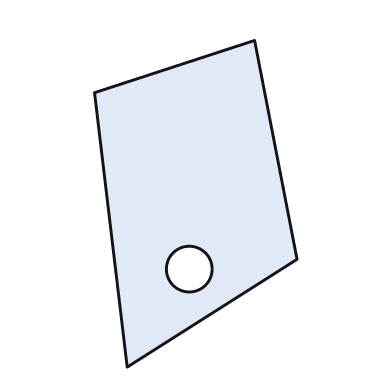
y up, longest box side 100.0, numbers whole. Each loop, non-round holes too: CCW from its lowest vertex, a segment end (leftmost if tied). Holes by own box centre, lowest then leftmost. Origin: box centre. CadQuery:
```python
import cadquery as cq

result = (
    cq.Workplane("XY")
    .moveTo(-21.0, -50.0)
    .lineTo(31.0, -17.0)
    .lineTo(18.0, 50.0)
    .lineTo(-31.0, 34.0)
    .close()
    .moveTo(-2.0, -20.0)
    .circle(7.0)
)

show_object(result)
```